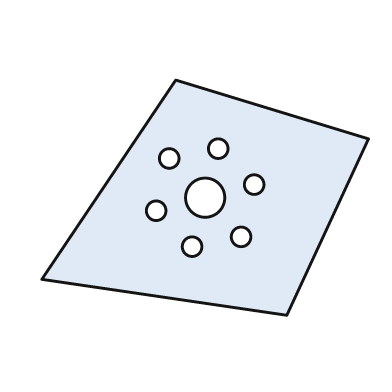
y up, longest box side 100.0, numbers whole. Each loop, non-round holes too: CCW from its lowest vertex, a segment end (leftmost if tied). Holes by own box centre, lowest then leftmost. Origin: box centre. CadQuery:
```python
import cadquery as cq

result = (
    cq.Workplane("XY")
    .moveTo(25.0, -36.0)
    .lineTo(50.0, 18.0)
    .lineTo(-9.0, 36.0)
    .lineTo(-50.0, -25.0)
    .close()
    .moveTo(-4.0, -15.0)
    .circle(3.0)
    .moveTo(11.0, -12.0)
    .circle(3.0)
    .moveTo(-15.0, -4.0)
    .circle(3.0)
    .moveTo(0.0, 0.0)
    .circle(6.0)
    .moveTo(15.0, 4.0)
    .circle(3.0)
    .moveTo(-11.0, 12.0)
    .circle(3.0)
    .moveTo(4.0, 15.0)
    .circle(3.0)
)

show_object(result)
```